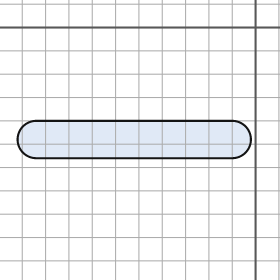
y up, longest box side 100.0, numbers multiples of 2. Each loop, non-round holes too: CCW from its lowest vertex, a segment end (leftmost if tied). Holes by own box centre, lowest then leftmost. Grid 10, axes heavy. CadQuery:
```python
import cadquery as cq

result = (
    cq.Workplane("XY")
    .moveTo(-94.0, -56.0)
    .lineTo(-10.0, -56.0)
    .threePointArc((-2.0, -48.0), (-10.0, -40.0))
    .lineTo(-94.0, -40.0)
    .threePointArc((-102.0, -48.0), (-94.0, -56.0))
    .close()
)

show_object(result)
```